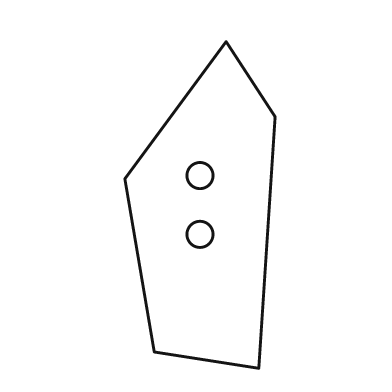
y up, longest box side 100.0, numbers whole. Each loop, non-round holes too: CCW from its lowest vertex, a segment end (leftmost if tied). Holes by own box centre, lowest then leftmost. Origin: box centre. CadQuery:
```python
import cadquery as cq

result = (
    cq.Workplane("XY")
    .moveTo(18.0, -50.0)
    .lineTo(23.0, 27.0)
    .lineTo(8.0, 50.0)
    .lineTo(-23.0, 8.0)
    .lineTo(-14.0, -45.0)
    .close()
    .moveTo(0.0, -9.0)
    .circle(4.0)
    .moveTo(0.0, 9.0)
    .circle(4.0)
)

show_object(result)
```